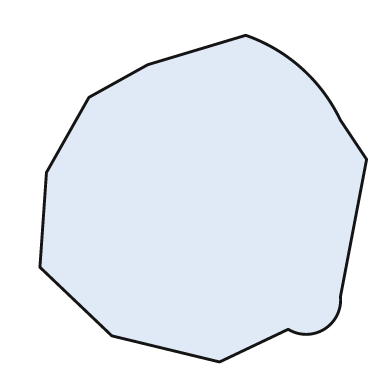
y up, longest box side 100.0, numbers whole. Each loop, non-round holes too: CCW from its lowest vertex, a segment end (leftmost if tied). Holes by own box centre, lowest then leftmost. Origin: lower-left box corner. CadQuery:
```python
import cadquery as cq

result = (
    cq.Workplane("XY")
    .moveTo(55.0, 0.0)
    .lineTo(76.0, 10.0)
    .threePointArc((87.0, 10.0), (92.0, 20.0))
    .lineTo(100.0, 62.0)
    .lineTo(92.0, 74.0)
    .threePointArc((80.0, 90.0), (63.0, 100.0))
    .lineTo(33.0, 91.0)
    .lineTo(15.0, 81.0)
    .lineTo(2.0, 58.0)
    .lineTo(0.0, 29.0)
    .lineTo(22.0, 8.0)
    .close()
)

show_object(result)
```